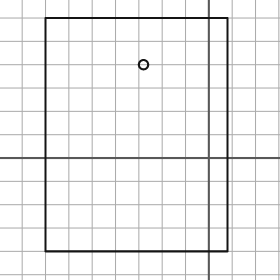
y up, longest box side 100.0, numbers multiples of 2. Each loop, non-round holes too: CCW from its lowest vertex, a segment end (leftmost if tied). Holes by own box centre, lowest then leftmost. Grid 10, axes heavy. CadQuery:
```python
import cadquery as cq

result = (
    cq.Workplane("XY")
    .moveTo(-70.0, -40.0)
    .lineTo(8.0, -40.0)
    .lineTo(8.0, 60.0)
    .lineTo(-70.0, 60.0)
    .close()
    .moveTo(-28.0, 40.0)
    .circle(2.0)
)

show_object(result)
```